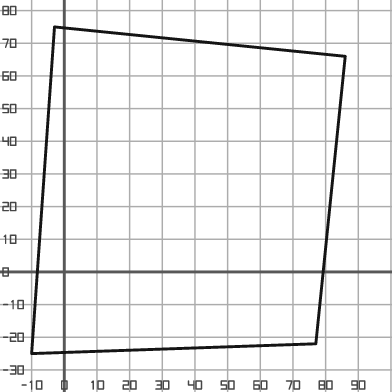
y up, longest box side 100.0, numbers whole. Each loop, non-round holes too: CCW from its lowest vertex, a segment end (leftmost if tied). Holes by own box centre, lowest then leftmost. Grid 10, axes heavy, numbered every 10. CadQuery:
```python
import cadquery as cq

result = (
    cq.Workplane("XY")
    .moveTo(-10.0, -25.0)
    .lineTo(77.0, -22.0)
    .lineTo(86.0, 66.0)
    .lineTo(-3.0, 75.0)
    .close()
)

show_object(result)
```